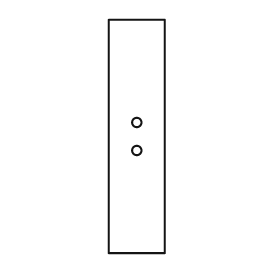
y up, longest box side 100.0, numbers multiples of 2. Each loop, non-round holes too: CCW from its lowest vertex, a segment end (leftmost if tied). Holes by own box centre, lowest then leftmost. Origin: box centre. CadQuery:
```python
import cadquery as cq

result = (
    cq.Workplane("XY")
    .moveTo(-12.0, -50.0)
    .lineTo(12.0, -50.0)
    .lineTo(12.0, 50.0)
    .lineTo(-12.0, 50.0)
    .close()
    .moveTo(0.0, -6.0)
    .circle(2.0)
    .moveTo(0.0, 6.0)
    .circle(2.0)
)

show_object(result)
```